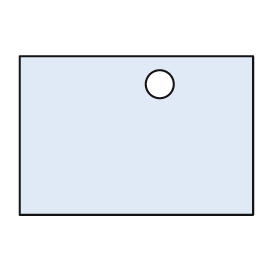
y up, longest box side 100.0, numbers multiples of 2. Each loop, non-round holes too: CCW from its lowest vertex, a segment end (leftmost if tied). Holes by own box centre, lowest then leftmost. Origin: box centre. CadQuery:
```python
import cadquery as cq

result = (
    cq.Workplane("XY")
    .moveTo(-50.0, -34.0)
    .lineTo(50.0, -34.0)
    .lineTo(50.0, 34.0)
    .lineTo(-50.0, 34.0)
    .close()
    .moveTo(10.0, 22.0)
    .circle(6.0)
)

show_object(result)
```